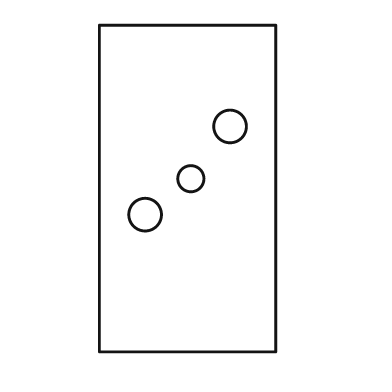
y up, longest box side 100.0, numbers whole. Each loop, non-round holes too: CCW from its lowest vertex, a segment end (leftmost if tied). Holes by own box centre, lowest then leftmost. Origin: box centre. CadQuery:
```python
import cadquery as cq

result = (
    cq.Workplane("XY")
    .moveTo(-27.0, -50.0)
    .lineTo(27.0, -50.0)
    .lineTo(27.0, 50.0)
    .lineTo(-27.0, 50.0)
    .close()
    .moveTo(-13.0, -8.0)
    .circle(5.0)
    .moveTo(1.0, 3.0)
    .circle(4.0)
    .moveTo(13.0, 19.0)
    .circle(5.0)
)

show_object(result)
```